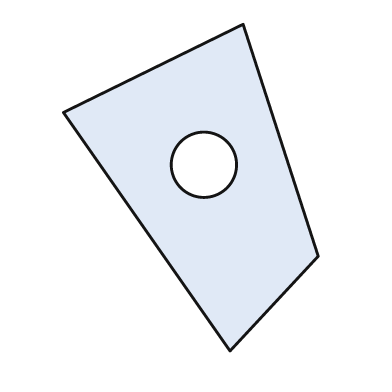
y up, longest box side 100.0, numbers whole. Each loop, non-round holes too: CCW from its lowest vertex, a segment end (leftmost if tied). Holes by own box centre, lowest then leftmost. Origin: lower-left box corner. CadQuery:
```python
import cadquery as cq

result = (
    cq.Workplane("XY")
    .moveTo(51.0, 0.0)
    .lineTo(78.0, 29.0)
    .lineTo(55.0, 100.0)
    .lineTo(0.0, 73.0)
    .close()
    .moveTo(43.0, 57.0)
    .circle(10.0)
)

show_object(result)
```